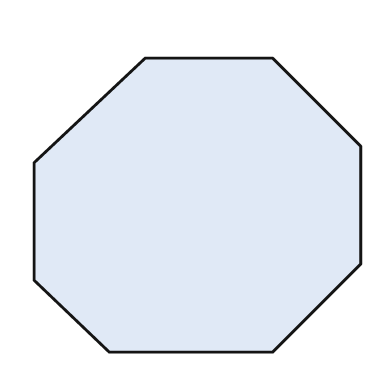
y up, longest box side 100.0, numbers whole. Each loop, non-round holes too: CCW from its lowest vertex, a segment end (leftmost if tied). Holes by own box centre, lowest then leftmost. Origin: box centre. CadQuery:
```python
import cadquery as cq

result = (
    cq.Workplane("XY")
    .moveTo(-27.0, -45.0)
    .lineTo(23.0, -45.0)
    .lineTo(50.0, -18.0)
    .lineTo(50.0, 18.0)
    .lineTo(23.0, 45.0)
    .lineTo(-16.0, 45.0)
    .lineTo(-50.0, 13.0)
    .lineTo(-50.0, -23.0)
    .close()
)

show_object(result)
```